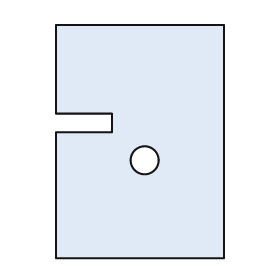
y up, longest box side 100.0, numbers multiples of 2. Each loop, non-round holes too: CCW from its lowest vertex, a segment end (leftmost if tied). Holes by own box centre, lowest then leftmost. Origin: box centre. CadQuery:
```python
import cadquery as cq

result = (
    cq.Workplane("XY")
    .moveTo(-36.0, -50.0)
    .lineTo(36.0, -50.0)
    .lineTo(36.0, 50.0)
    .lineTo(-36.0, 50.0)
    .lineTo(-36.0, 12.0)
    .lineTo(-12.0, 12.0)
    .lineTo(-12.0, 4.0)
    .lineTo(-36.0, 4.0)
    .close()
    .moveTo(2.0, -8.0)
    .circle(6.0)
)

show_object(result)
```